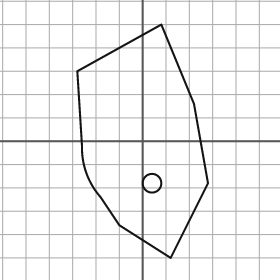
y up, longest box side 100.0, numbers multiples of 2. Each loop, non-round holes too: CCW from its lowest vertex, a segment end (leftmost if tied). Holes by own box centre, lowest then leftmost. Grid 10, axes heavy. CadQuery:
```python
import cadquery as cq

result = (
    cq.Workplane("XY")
    .moveTo(12.0, -50.0)
    .lineTo(28.0, -18.0)
    .lineTo(22.0, 16.0)
    .lineTo(8.0, 50.0)
    .lineTo(-28.0, 30.0)
    .lineTo(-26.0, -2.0)
    .threePointArc((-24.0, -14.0), (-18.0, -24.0))
    .lineTo(-10.0, -36.0)
    .close()
    .moveTo(4.0, -18.0)
    .circle(4.0)
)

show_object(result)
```